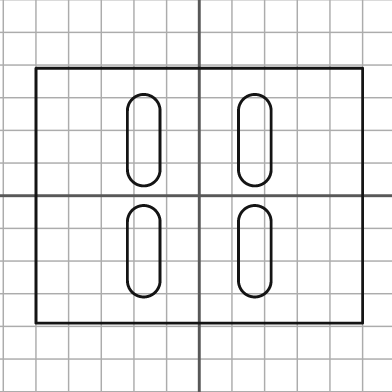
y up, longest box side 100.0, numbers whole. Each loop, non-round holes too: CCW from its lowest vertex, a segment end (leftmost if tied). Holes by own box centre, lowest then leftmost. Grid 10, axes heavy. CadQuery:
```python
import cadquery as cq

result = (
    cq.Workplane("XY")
    .moveTo(-50.0, -39.0)
    .lineTo(50.0, -39.0)
    .lineTo(50.0, 39.0)
    .lineTo(-50.0, 39.0)
    .close()
    .moveTo(-22.0, -26.0)
    .threePointArc((-17.0, -31.0), (-12.0, -26.0))
    .lineTo(-12.0, -8.0)
    .threePointArc((-17.0, -3.0), (-22.0, -8.0))
    .close()
    .moveTo(12.0, -26.0)
    .threePointArc((17.0, -31.0), (22.0, -26.0))
    .lineTo(22.0, -8.0)
    .threePointArc((17.0, -3.0), (12.0, -8.0))
    .close()
    .moveTo(-22.0, 8.0)
    .threePointArc((-17.0, 3.0), (-12.0, 8.0))
    .lineTo(-12.0, 26.0)
    .threePointArc((-17.0, 31.0), (-22.0, 26.0))
    .close()
    .moveTo(12.0, 8.0)
    .threePointArc((17.0, 3.0), (22.0, 8.0))
    .lineTo(22.0, 26.0)
    .threePointArc((17.0, 31.0), (12.0, 26.0))
    .close()
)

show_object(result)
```